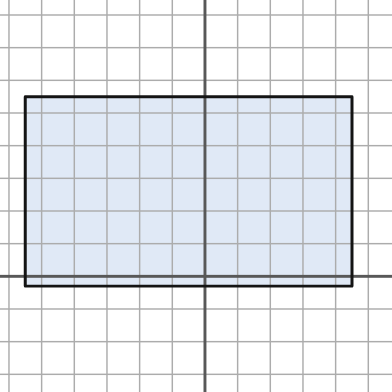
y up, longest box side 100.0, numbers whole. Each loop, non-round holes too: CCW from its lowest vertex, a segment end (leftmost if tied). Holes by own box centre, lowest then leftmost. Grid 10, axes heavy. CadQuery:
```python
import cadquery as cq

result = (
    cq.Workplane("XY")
    .moveTo(-55.0, -3.0)
    .lineTo(45.0, -3.0)
    .lineTo(45.0, 55.0)
    .lineTo(-55.0, 55.0)
    .close()
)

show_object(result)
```